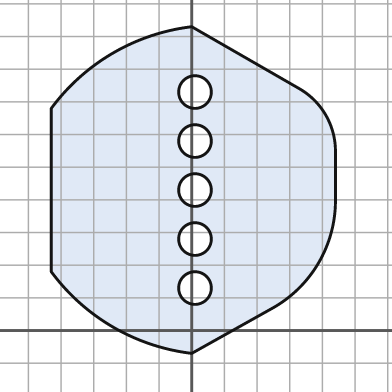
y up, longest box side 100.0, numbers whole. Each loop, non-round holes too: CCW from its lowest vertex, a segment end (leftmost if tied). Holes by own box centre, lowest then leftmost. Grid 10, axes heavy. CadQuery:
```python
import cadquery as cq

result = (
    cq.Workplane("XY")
    .moveTo(0.0, -7.0)
    .lineTo(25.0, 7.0)
    .threePointArc((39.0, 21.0), (44.0, 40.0))
    .lineTo(44.0, 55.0)
    .threePointArc((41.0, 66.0), (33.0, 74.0))
    .lineTo(0.0, 93.0)
    .threePointArc((-24.0, 85.0), (-43.0, 68.0))
    .lineTo(-43.0, 18.0)
    .threePointArc((-24.0, 1.0), (0.0, -7.0))
    .close()
    .moveTo(1.0, 13.0)
    .circle(5.0)
    .moveTo(1.0, 28.0)
    .circle(5.0)
    .moveTo(1.0, 43.0)
    .circle(5.0)
    .moveTo(1.0, 58.0)
    .circle(5.0)
    .moveTo(1.0, 73.0)
    .circle(5.0)
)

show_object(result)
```